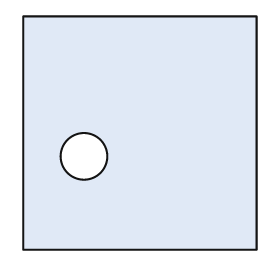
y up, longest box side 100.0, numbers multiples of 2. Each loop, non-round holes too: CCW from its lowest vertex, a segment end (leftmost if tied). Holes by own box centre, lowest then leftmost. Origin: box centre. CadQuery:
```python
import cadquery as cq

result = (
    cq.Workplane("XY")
    .moveTo(-50.0, -50.0)
    .lineTo(50.0, -50.0)
    .lineTo(50.0, 50.0)
    .lineTo(-50.0, 50.0)
    .close()
    .moveTo(-24.0, -10.0)
    .circle(10.0)
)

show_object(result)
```